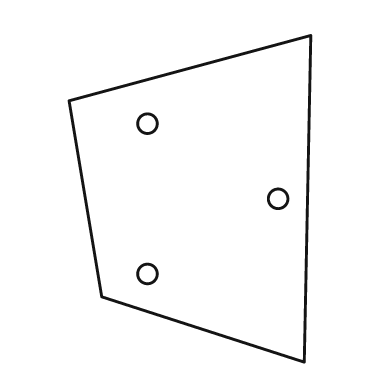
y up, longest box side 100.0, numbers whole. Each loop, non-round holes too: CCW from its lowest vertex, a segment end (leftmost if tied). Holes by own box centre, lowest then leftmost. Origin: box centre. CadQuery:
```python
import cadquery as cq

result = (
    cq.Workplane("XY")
    .moveTo(35.0, -50.0)
    .lineTo(37.0, 50.0)
    .lineTo(-37.0, 30.0)
    .lineTo(-27.0, -30.0)
    .close()
    .moveTo(-13.0, -23.0)
    .circle(3.0)
    .moveTo(27.0, 0.0)
    .circle(3.0)
    .moveTo(-13.0, 23.0)
    .circle(3.0)
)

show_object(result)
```